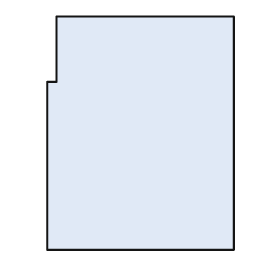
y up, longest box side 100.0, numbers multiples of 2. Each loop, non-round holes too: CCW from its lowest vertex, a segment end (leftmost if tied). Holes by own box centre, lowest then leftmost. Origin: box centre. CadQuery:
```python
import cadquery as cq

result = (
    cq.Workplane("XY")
    .moveTo(-40.0, -50.0)
    .lineTo(40.0, -50.0)
    .lineTo(40.0, 50.0)
    .lineTo(-36.0, 50.0)
    .lineTo(-36.0, 22.0)
    .lineTo(-40.0, 22.0)
    .close()
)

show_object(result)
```